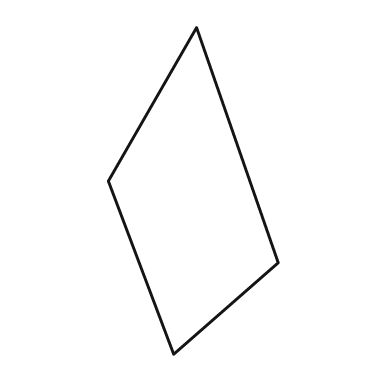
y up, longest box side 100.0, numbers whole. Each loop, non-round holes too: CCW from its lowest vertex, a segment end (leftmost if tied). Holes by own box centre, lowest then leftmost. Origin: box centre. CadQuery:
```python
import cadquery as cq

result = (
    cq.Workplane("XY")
    .moveTo(-6.0, -50.0)
    .lineTo(26.0, -22.0)
    .lineTo(1.0, 50.0)
    .lineTo(-26.0, 3.0)
    .close()
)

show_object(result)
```